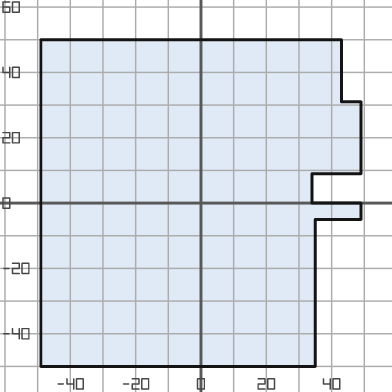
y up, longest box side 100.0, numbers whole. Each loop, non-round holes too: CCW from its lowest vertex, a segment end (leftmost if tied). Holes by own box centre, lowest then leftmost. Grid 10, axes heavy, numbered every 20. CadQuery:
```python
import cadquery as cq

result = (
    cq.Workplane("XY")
    .moveTo(-49.0, -50.0)
    .lineTo(35.0, -50.0)
    .lineTo(35.0, -5.0)
    .lineTo(49.0, -5.0)
    .lineTo(49.0, 0.0)
    .lineTo(34.0, 0.0)
    .lineTo(34.0, 9.0)
    .lineTo(49.0, 9.0)
    .lineTo(49.0, 31.0)
    .lineTo(43.0, 31.0)
    .lineTo(43.0, 50.0)
    .lineTo(-49.0, 50.0)
    .close()
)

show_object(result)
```